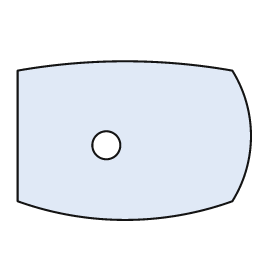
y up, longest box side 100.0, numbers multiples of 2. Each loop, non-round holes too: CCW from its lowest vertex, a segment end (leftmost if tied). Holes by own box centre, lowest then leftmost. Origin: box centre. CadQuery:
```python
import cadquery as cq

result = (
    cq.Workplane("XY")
    .moveTo(-50.0, -26.0)
    .threePointArc((-4.0, -34.0), (42.0, -26.0))
    .threePointArc((50.0, 2.0), (42.0, 30.0))
    .threePointArc((-4.0, 34.0), (-50.0, 30.0))
    .close()
    .moveTo(-12.0, -2.0)
    .circle(6.0)
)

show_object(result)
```